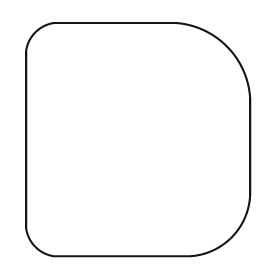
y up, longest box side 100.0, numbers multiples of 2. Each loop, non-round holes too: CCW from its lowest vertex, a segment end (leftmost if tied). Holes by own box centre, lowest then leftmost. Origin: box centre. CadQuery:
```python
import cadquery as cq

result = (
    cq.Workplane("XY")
    .moveTo(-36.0, -50.0)
    .lineTo(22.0, -50.0)
    .threePointArc((40.0, -42.0), (48.0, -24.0))
    .lineTo(48.0, 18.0)
    .threePointArc((38.0, 40.0), (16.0, 50.0))
    .lineTo(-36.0, 50.0)
    .threePointArc((-44.0, 46.0), (-48.0, 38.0))
    .lineTo(-48.0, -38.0)
    .threePointArc((-44.0, -46.0), (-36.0, -50.0))
    .close()
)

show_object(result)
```